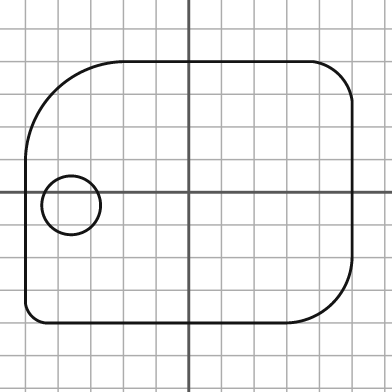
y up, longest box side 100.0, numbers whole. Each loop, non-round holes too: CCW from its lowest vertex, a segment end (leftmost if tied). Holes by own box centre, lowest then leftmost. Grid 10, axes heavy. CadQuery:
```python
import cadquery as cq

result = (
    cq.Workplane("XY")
    .moveTo(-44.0, -40.0)
    .lineTo(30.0, -40.0)
    .threePointArc((44.0, -34.0), (50.0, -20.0))
    .lineTo(50.0, 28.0)
    .threePointArc((46.0, 36.0), (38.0, 40.0))
    .lineTo(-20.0, 40.0)
    .threePointArc((-41.0, 31.0), (-50.0, 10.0))
    .lineTo(-50.0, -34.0)
    .threePointArc((-48.0, -38.0), (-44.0, -40.0))
    .close()
    .moveTo(-36.0, -4.0)
    .circle(9.0)
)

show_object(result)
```